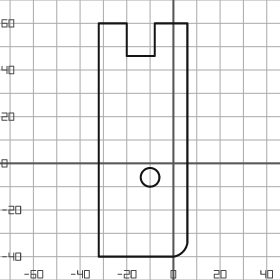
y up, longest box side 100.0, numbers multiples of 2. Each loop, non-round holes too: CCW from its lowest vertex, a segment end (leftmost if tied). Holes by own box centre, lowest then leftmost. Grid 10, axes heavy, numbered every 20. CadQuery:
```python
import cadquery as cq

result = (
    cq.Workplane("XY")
    .moveTo(-32.0, -40.0)
    .lineTo(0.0, -40.0)
    .threePointArc((4.0, -38.0), (6.0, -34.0))
    .lineTo(6.0, 60.0)
    .lineTo(-8.0, 60.0)
    .lineTo(-8.0, 46.0)
    .lineTo(-20.0, 46.0)
    .lineTo(-20.0, 60.0)
    .lineTo(-32.0, 60.0)
    .close()
    .moveTo(-10.0, -6.0)
    .circle(4.0)
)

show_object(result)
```